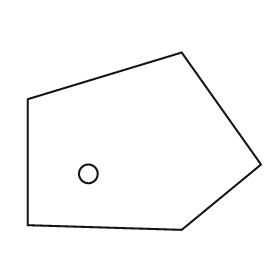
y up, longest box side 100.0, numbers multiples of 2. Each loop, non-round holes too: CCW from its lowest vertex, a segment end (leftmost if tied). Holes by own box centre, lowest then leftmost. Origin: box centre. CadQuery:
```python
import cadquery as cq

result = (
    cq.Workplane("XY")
    .moveTo(16.0, -38.0)
    .lineTo(50.0, -10.0)
    .lineTo(16.0, 38.0)
    .lineTo(-50.0, 18.0)
    .lineTo(-50.0, -36.0)
    .close()
    .moveTo(-24.0, -14.0)
    .circle(4.0)
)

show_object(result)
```